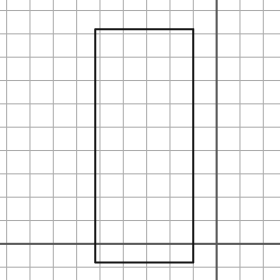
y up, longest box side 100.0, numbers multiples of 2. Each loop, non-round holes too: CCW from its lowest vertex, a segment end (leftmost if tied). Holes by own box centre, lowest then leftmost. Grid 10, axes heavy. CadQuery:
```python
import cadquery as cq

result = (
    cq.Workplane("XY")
    .moveTo(-52.0, -8.0)
    .lineTo(-10.0, -8.0)
    .lineTo(-10.0, 92.0)
    .lineTo(-52.0, 92.0)
    .close()
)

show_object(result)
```